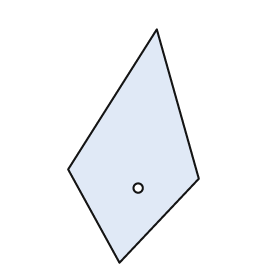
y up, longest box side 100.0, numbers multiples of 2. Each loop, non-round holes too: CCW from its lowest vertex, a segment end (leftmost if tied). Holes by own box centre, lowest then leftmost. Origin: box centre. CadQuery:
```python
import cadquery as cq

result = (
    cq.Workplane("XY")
    .moveTo(-6.0, -50.0)
    .lineTo(28.0, -14.0)
    .lineTo(10.0, 50.0)
    .lineTo(-28.0, -10.0)
    .close()
    .moveTo(2.0, -18.0)
    .circle(2.0)
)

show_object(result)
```